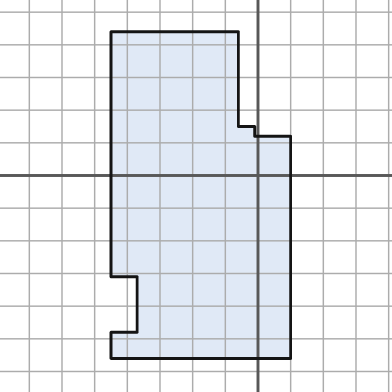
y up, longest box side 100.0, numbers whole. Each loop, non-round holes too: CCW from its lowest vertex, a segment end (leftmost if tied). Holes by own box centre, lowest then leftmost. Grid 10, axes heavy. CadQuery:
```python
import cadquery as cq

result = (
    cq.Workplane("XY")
    .moveTo(-45.0, -56.0)
    .lineTo(10.0, -56.0)
    .lineTo(10.0, 12.0)
    .lineTo(-1.0, 12.0)
    .lineTo(-1.0, 15.0)
    .lineTo(-6.0, 15.0)
    .lineTo(-6.0, 44.0)
    .lineTo(-45.0, 44.0)
    .lineTo(-45.0, -31.0)
    .lineTo(-37.0, -31.0)
    .lineTo(-37.0, -48.0)
    .lineTo(-45.0, -48.0)
    .close()
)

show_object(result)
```